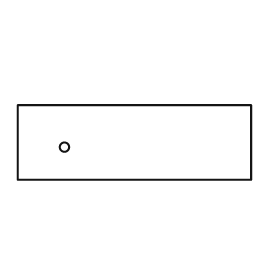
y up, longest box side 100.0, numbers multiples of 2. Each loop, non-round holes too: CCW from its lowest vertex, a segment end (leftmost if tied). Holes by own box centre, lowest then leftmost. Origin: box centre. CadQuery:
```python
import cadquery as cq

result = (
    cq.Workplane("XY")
    .moveTo(-50.0, -16.0)
    .lineTo(50.0, -16.0)
    .lineTo(50.0, 16.0)
    .lineTo(-50.0, 16.0)
    .close()
    .moveTo(-30.0, -2.0)
    .circle(2.0)
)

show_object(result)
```